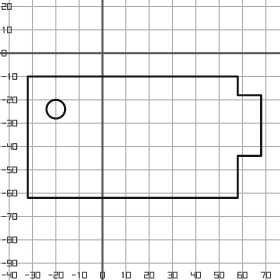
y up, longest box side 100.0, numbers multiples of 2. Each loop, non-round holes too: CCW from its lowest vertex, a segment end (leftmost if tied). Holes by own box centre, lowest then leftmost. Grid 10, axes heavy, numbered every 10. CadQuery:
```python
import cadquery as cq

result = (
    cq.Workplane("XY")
    .moveTo(-32.0, -62.0)
    .lineTo(58.0, -62.0)
    .lineTo(58.0, -44.0)
    .lineTo(68.0, -44.0)
    .lineTo(68.0, -18.0)
    .lineTo(58.0, -18.0)
    .lineTo(58.0, -10.0)
    .lineTo(-32.0, -10.0)
    .close()
    .moveTo(-20.0, -24.0)
    .circle(4.0)
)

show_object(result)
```